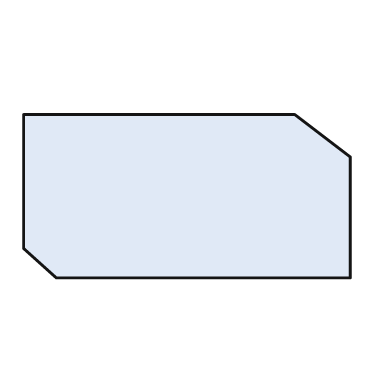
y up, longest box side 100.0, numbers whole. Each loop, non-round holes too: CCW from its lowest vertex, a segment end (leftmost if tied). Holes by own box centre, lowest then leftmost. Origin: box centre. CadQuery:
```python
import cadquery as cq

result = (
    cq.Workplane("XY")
    .moveTo(-40.0, -25.0)
    .lineTo(50.0, -25.0)
    .lineTo(50.0, 12.0)
    .lineTo(33.0, 25.0)
    .lineTo(-50.0, 25.0)
    .lineTo(-50.0, -16.0)
    .close()
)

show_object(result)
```